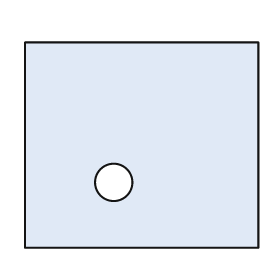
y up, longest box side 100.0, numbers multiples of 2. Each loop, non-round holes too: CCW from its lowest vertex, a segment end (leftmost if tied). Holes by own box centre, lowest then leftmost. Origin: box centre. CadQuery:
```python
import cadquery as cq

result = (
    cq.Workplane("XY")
    .moveTo(-50.0, -44.0)
    .lineTo(50.0, -44.0)
    .lineTo(50.0, 44.0)
    .lineTo(-50.0, 44.0)
    .close()
    .moveTo(-12.0, -16.0)
    .circle(8.0)
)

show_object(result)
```